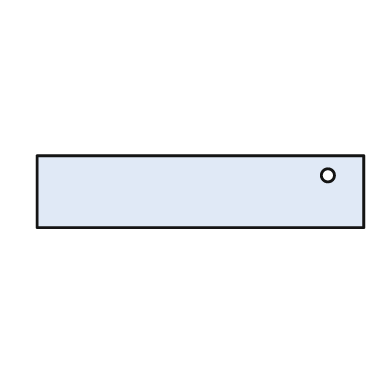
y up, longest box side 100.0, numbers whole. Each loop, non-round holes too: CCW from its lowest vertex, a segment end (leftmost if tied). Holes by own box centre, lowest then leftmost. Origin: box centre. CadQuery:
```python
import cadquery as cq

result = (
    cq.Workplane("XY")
    .moveTo(-50.0, -11.0)
    .lineTo(50.0, -11.0)
    .lineTo(50.0, 11.0)
    .lineTo(-50.0, 11.0)
    .close()
    .moveTo(39.0, 5.0)
    .circle(2.0)
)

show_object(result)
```